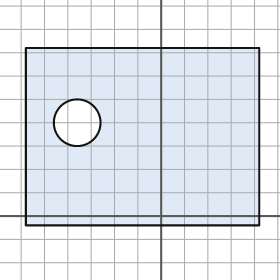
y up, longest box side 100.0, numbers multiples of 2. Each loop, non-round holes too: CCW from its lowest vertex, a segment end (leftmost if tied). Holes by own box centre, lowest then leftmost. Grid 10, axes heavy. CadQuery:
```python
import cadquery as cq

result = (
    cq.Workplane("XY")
    .moveTo(-58.0, -4.0)
    .lineTo(42.0, -4.0)
    .lineTo(42.0, 72.0)
    .lineTo(-58.0, 72.0)
    .close()
    .moveTo(-36.0, 40.0)
    .circle(10.0)
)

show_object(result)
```